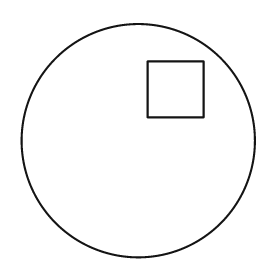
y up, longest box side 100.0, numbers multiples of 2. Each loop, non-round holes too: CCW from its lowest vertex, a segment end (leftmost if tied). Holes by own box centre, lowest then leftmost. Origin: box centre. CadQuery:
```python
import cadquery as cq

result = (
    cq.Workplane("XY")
    .moveTo(0.0, 0.0)
    .circle(50.0)
    .moveTo(4.0, 10.0)
    .lineTo(28.0, 10.0)
    .lineTo(28.0, 34.0)
    .lineTo(4.0, 34.0)
    .close()
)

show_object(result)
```